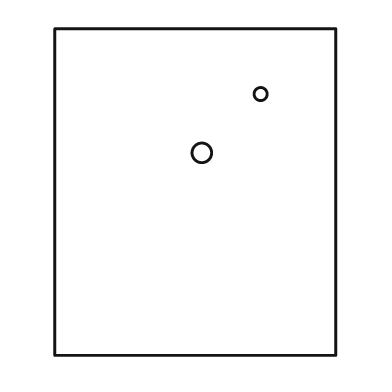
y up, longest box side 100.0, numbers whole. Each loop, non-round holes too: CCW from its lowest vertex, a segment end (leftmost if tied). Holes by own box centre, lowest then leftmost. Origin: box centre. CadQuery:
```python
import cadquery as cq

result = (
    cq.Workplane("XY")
    .moveTo(-43.0, -50.0)
    .lineTo(43.0, -50.0)
    .lineTo(43.0, 50.0)
    .lineTo(-43.0, 50.0)
    .close()
    .moveTo(2.0, 12.0)
    .circle(3.0)
    .moveTo(20.0, 30.0)
    .circle(2.0)
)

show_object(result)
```